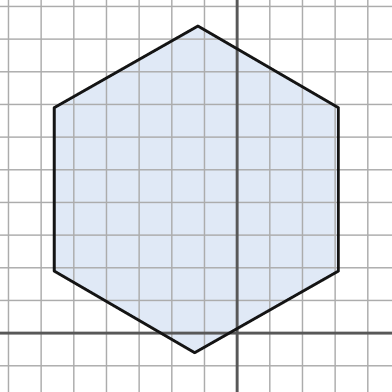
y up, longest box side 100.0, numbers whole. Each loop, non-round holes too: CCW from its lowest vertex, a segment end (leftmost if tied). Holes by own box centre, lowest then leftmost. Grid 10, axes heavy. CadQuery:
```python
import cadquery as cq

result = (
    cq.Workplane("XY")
    .moveTo(-13.0, -6.0)
    .lineTo(31.0, 19.0)
    .lineTo(31.0, 69.0)
    .lineTo(-12.0, 94.0)
    .lineTo(-56.0, 69.0)
    .lineTo(-56.0, 19.0)
    .close()
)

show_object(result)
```